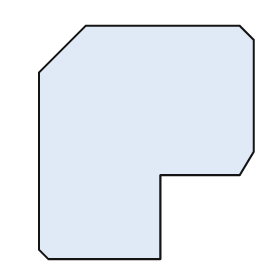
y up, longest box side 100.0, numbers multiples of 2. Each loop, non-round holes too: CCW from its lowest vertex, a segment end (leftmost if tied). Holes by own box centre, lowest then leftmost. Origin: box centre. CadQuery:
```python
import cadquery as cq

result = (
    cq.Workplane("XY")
    .moveTo(-42.0, -50.0)
    .lineTo(6.0, -50.0)
    .lineTo(6.0, -14.0)
    .lineTo(40.0, -14.0)
    .lineTo(46.0, -4.0)
    .lineTo(46.0, 44.0)
    .lineTo(40.0, 50.0)
    .lineTo(-26.0, 50.0)
    .lineTo(-46.0, 30.0)
    .lineTo(-46.0, -46.0)
    .close()
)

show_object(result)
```